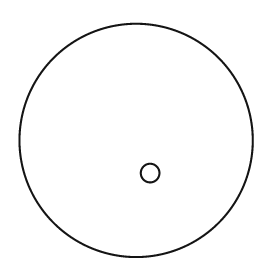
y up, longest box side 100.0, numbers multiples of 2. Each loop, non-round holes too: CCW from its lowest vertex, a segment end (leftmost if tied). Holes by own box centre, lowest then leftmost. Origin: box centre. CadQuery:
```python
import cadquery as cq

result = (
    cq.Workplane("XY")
    .moveTo(0.0, 0.0)
    .circle(50.0)
    .moveTo(6.0, -14.0)
    .circle(4.0)
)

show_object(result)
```